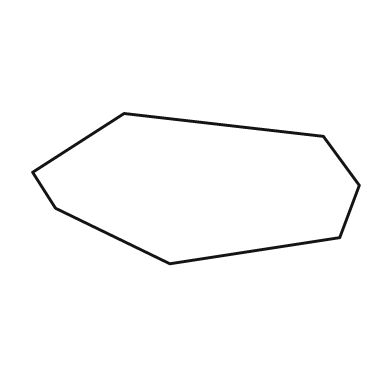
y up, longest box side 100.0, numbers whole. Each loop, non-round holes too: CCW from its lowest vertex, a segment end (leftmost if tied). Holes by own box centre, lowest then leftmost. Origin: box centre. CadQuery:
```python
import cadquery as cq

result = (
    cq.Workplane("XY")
    .moveTo(-8.0, -23.0)
    .lineTo(44.0, -15.0)
    .lineTo(50.0, 1.0)
    .lineTo(39.0, 16.0)
    .lineTo(-22.0, 23.0)
    .lineTo(-50.0, 5.0)
    .lineTo(-43.0, -6.0)
    .close()
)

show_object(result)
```